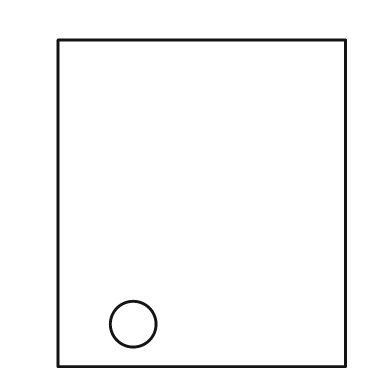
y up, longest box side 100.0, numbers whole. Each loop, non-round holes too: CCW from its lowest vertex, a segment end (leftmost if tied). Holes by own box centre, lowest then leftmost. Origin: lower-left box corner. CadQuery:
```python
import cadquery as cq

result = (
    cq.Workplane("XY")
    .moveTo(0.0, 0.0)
    .lineTo(88.0, 0.0)
    .lineTo(88.0, 100.0)
    .lineTo(0.0, 100.0)
    .close()
    .moveTo(23.0, 13.0)
    .circle(7.0)
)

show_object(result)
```